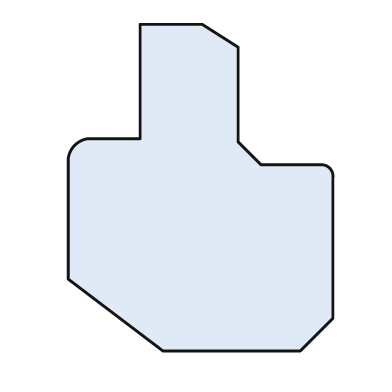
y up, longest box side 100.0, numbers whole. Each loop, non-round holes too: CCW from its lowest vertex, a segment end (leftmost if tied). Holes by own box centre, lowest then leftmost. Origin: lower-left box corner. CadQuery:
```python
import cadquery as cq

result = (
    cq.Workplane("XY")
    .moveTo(29.0, 0.0)
    .lineTo(71.0, 0.0)
    .lineTo(81.0, 10.0)
    .lineTo(81.0, 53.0)
    .threePointArc((80.0, 56.0), (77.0, 57.0))
    .lineTo(59.0, 57.0)
    .lineTo(52.0, 64.0)
    .lineTo(52.0, 93.0)
    .lineTo(41.0, 100.0)
    .lineTo(22.0, 100.0)
    .lineTo(22.0, 65.0)
    .lineTo(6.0, 65.0)
    .threePointArc((2.0, 63.0), (0.0, 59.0))
    .lineTo(0.0, 22.0)
    .close()
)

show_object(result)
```